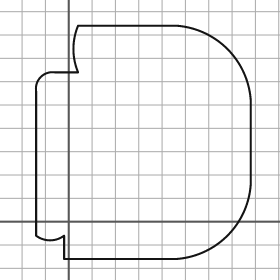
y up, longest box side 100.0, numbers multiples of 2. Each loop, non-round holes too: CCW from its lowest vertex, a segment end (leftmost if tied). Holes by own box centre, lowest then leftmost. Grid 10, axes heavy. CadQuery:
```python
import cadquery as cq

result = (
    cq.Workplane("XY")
    .moveTo(-2.0, -16.0)
    .lineTo(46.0, -16.0)
    .threePointArc((68.0, -6.0), (78.0, 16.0))
    .lineTo(78.0, 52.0)
    .threePointArc((68.0, 74.0), (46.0, 84.0))
    .lineTo(4.0, 84.0)
    .threePointArc((2.0, 74.0), (4.0, 64.0))
    .lineTo(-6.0, 64.0)
    .threePointArc((-12.0, 62.0), (-14.0, 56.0))
    .lineTo(-14.0, -6.0)
    .threePointArc((-8.0, -8.0), (-2.0, -6.0))
    .close()
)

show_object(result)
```